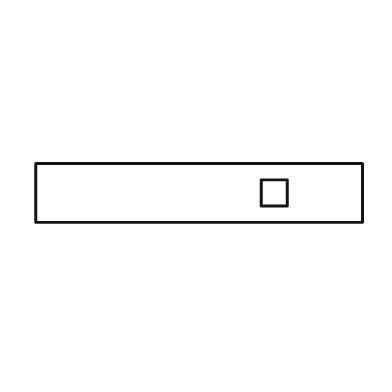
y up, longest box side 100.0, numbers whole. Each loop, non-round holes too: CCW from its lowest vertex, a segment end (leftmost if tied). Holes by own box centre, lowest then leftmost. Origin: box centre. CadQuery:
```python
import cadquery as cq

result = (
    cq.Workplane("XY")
    .moveTo(-50.0, -9.0)
    .lineTo(50.0, -9.0)
    .lineTo(50.0, 9.0)
    .lineTo(-50.0, 9.0)
    .close()
    .moveTo(19.0, -4.0)
    .lineTo(27.0, -4.0)
    .lineTo(27.0, 4.0)
    .lineTo(19.0, 4.0)
    .close()
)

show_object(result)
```